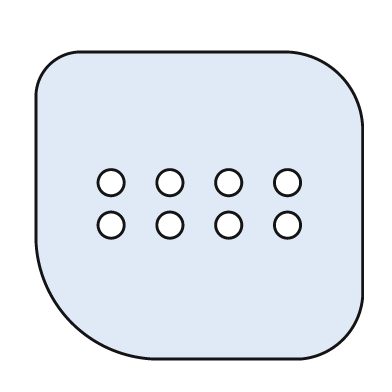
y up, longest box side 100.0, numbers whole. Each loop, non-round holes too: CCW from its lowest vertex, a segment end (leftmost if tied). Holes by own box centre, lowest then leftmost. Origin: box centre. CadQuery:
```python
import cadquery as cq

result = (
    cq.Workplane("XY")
    .moveTo(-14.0, -47.0)
    .lineTo(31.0, -47.0)
    .threePointArc((44.0, -41.0), (50.0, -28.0))
    .lineTo(50.0, 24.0)
    .threePointArc((43.0, 40.0), (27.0, 47.0))
    .lineTo(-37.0, 47.0)
    .threePointArc((-46.0, 43.0), (-50.0, 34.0))
    .lineTo(-50.0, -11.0)
    .threePointArc((-39.0, -36.0), (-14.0, -47.0))
    .close()
    .moveTo(-27.0, -6.0)
    .circle(4.0)
    .moveTo(-9.0, -6.0)
    .circle(4.0)
    .moveTo(9.0, -6.0)
    .circle(4.0)
    .moveTo(27.0, -6.0)
    .circle(4.0)
    .moveTo(-27.0, 7.0)
    .circle(4.0)
    .moveTo(-9.0, 7.0)
    .circle(4.0)
    .moveTo(9.0, 7.0)
    .circle(4.0)
    .moveTo(27.0, 7.0)
    .circle(4.0)
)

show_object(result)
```